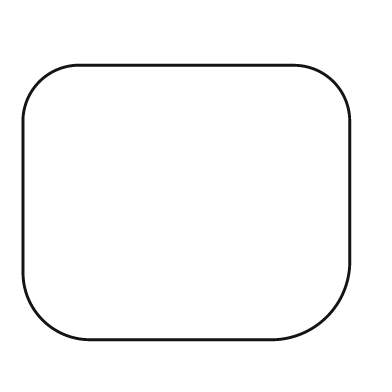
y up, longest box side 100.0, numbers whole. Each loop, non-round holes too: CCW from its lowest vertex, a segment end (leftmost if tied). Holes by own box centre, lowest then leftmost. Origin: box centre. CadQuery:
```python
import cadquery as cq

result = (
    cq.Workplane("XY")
    .moveTo(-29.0, -42.0)
    .lineTo(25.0, -42.0)
    .threePointArc((43.0, -35.0), (50.0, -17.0))
    .lineTo(50.0, 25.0)
    .threePointArc((45.0, 37.0), (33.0, 42.0))
    .lineTo(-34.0, 42.0)
    .threePointArc((-45.0, 37.0), (-50.0, 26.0))
    .lineTo(-50.0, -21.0)
    .threePointArc((-44.0, -36.0), (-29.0, -42.0))
    .close()
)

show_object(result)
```